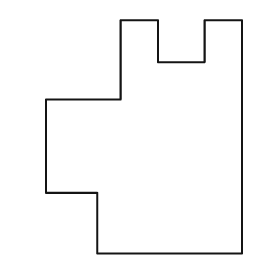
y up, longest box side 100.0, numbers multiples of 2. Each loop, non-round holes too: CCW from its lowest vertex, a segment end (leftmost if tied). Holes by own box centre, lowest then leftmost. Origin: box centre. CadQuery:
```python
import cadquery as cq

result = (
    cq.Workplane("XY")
    .moveTo(-20.0, -50.0)
    .lineTo(42.0, -50.0)
    .lineTo(42.0, 50.0)
    .lineTo(26.0, 50.0)
    .lineTo(26.0, 32.0)
    .lineTo(6.0, 32.0)
    .lineTo(6.0, 50.0)
    .lineTo(-10.0, 50.0)
    .lineTo(-10.0, 16.0)
    .lineTo(-42.0, 16.0)
    .lineTo(-42.0, -24.0)
    .lineTo(-20.0, -24.0)
    .close()
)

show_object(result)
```